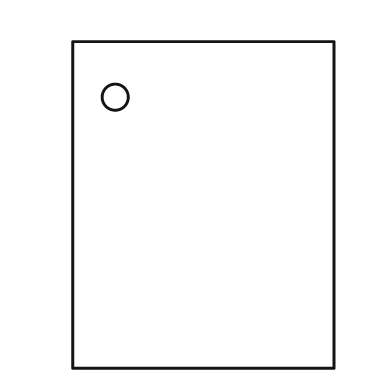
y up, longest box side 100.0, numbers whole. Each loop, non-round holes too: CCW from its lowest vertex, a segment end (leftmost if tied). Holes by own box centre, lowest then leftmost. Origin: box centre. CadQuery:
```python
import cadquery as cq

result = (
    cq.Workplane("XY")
    .moveTo(-40.0, -50.0)
    .lineTo(40.0, -50.0)
    .lineTo(40.0, 50.0)
    .lineTo(-40.0, 50.0)
    .close()
    .moveTo(-27.0, 33.0)
    .circle(4.0)
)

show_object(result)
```